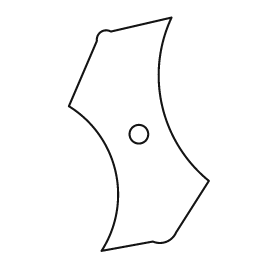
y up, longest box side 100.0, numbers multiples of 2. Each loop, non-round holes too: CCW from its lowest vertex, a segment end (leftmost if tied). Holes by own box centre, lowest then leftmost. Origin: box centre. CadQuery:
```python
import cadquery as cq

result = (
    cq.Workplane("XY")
    .moveTo(-16.0, -50.0)
    .lineTo(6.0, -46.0)
    .threePointArc((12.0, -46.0), (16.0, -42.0))
    .lineTo(30.0, -20.0)
    .threePointArc((10.0, 12.0), (14.0, 50.0))
    .lineTo(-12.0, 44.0)
    .threePointArc((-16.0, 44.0), (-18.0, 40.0))
    .lineTo(-30.0, 12.0)
    .threePointArc((-10.0, -16.0), (-16.0, -50.0))
    .close()
    .moveTo(0.0, 0.0)
    .circle(4.0)
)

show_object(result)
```